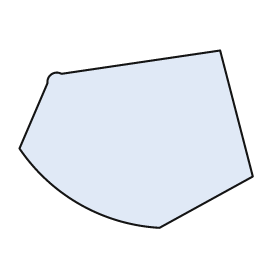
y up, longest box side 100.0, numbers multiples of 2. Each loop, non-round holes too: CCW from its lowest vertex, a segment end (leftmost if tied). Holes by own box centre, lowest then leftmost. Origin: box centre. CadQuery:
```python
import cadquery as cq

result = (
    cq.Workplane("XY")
    .moveTo(10.0, -38.0)
    .lineTo(50.0, -16.0)
    .lineTo(36.0, 38.0)
    .lineTo(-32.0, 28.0)
    .threePointArc((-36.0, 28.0), (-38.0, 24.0))
    .lineTo(-50.0, -4.0)
    .threePointArc((-24.0, -28.0), (10.0, -38.0))
    .close()
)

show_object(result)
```